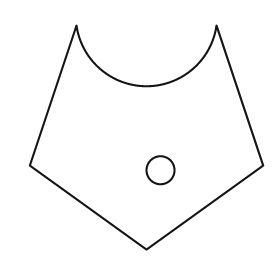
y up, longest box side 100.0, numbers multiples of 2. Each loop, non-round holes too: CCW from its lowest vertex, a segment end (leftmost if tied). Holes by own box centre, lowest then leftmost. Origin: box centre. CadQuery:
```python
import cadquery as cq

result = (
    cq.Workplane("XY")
    .moveTo(0.0, -48.0)
    .lineTo(50.0, -12.0)
    .lineTo(30.0, 48.0)
    .threePointArc((0.0, 22.0), (-30.0, 48.0))
    .lineTo(-50.0, -12.0)
    .close()
    .moveTo(6.0, -14.0)
    .circle(6.0)
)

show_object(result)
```